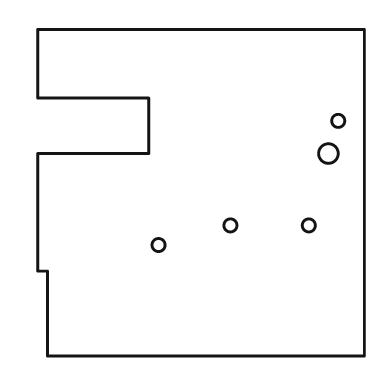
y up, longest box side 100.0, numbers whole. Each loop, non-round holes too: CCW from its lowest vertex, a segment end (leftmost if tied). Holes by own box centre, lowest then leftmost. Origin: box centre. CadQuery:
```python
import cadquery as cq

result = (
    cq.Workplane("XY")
    .moveTo(-47.0, -50.0)
    .lineTo(50.0, -50.0)
    .lineTo(50.0, 50.0)
    .lineTo(-50.0, 50.0)
    .lineTo(-50.0, 29.0)
    .lineTo(-16.0, 29.0)
    .lineTo(-16.0, 12.0)
    .lineTo(-50.0, 12.0)
    .lineTo(-50.0, -24.0)
    .lineTo(-47.0, -24.0)
    .close()
    .moveTo(-13.0, -16.0)
    .circle(2.0)
    .moveTo(9.0, -10.0)
    .circle(2.0)
    .moveTo(33.0, -10.0)
    .circle(2.0)
    .moveTo(39.0, 12.0)
    .circle(3.0)
    .moveTo(42.0, 22.0)
    .circle(2.0)
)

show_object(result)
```